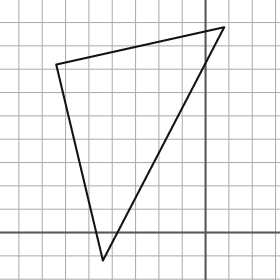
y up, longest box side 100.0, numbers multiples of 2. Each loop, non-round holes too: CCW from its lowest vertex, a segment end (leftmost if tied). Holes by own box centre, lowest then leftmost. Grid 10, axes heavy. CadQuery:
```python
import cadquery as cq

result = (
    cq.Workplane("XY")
    .moveTo(-44.0, -12.0)
    .lineTo(8.0, 88.0)
    .lineTo(-64.0, 72.0)
    .close()
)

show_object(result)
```